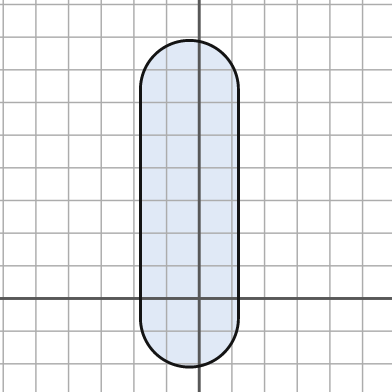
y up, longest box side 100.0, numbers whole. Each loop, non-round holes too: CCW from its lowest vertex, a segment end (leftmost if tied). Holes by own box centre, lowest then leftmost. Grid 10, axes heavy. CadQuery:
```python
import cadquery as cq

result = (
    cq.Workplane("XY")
    .moveTo(-18.0, -6.0)
    .threePointArc((-3.0, -21.0), (12.0, -6.0))
    .lineTo(12.0, 64.0)
    .threePointArc((-3.0, 79.0), (-18.0, 64.0))
    .close()
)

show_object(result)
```